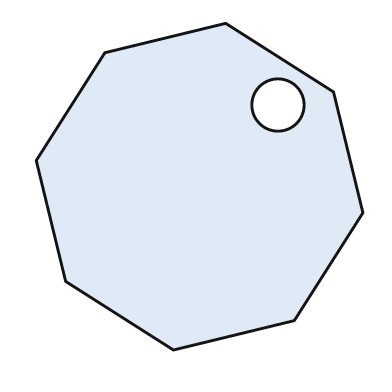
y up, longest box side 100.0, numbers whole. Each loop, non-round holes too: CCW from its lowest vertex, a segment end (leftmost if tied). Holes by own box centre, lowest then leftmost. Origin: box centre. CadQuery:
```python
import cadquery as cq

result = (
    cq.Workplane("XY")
    .moveTo(-8.0, -50.0)
    .lineTo(29.0, -41.0)
    .lineTo(50.0, -8.0)
    .lineTo(41.0, 29.0)
    .lineTo(8.0, 50.0)
    .lineTo(-29.0, 41.0)
    .lineTo(-50.0, 8.0)
    .lineTo(-41.0, -29.0)
    .close()
    .moveTo(24.0, 25.0)
    .circle(8.0)
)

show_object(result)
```